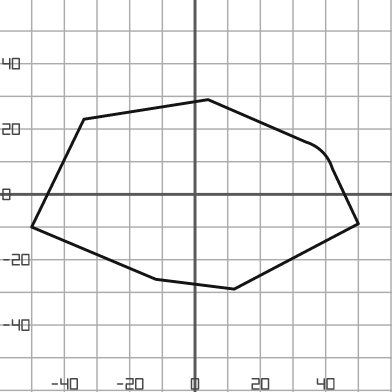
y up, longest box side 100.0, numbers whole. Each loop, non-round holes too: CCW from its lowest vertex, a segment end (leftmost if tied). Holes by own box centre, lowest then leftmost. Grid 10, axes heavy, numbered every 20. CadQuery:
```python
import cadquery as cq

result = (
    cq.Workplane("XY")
    .moveTo(12.0, -29.0)
    .lineTo(50.0, -9.0)
    .lineTo(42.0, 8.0)
    .threePointArc((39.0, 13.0), (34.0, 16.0))
    .lineTo(4.0, 29.0)
    .lineTo(-34.0, 23.0)
    .lineTo(-50.0, -10.0)
    .lineTo(-12.0, -26.0)
    .close()
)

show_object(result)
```